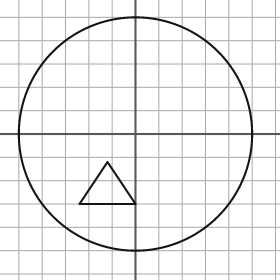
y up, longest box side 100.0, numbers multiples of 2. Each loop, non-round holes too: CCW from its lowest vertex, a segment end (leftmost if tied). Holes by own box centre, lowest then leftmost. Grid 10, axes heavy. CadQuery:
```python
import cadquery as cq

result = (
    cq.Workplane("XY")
    .moveTo(0.0, 0.0)
    .circle(50.0)
    .moveTo(-24.0, -30.0)
    .lineTo(0.0, -30.0)
    .lineTo(-12.0, -12.0)
    .close()
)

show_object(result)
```